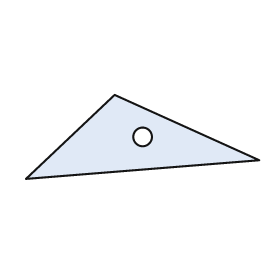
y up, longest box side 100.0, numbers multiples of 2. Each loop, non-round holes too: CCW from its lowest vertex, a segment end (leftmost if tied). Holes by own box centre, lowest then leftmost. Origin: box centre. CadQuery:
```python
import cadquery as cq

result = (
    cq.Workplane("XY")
    .moveTo(-50.0, -18.0)
    .lineTo(50.0, -10.0)
    .lineTo(-12.0, 18.0)
    .close()
    .moveTo(0.0, 0.0)
    .circle(4.0)
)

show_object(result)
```